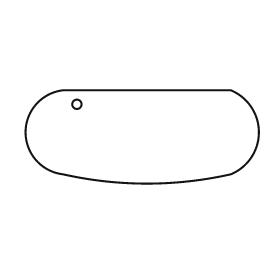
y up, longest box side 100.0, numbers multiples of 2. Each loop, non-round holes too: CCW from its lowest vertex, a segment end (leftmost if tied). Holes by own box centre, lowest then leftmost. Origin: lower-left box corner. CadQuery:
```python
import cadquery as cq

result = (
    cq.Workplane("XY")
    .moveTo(16.0, 4.0)
    .threePointArc((52.0, 0.0), (88.0, 4.0))
    .threePointArc((100.0, 22.0), (88.0, 40.0))
    .lineTo(16.0, 40.0)
    .threePointArc((0.0, 22.0), (16.0, 4.0))
    .close()
    .moveTo(22.0, 34.0)
    .circle(2.0)
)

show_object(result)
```